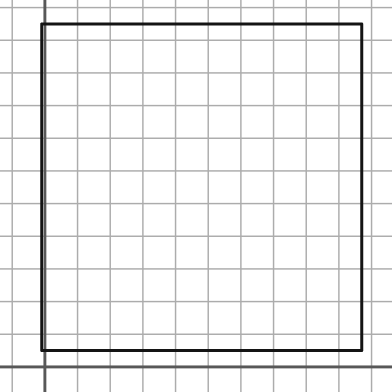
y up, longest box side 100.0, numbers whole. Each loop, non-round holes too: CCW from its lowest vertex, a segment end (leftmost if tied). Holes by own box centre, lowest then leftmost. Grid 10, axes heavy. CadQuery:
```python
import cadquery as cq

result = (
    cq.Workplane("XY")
    .moveTo(-1.0, 5.0)
    .lineTo(97.0, 5.0)
    .lineTo(97.0, 105.0)
    .lineTo(-1.0, 105.0)
    .close()
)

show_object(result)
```